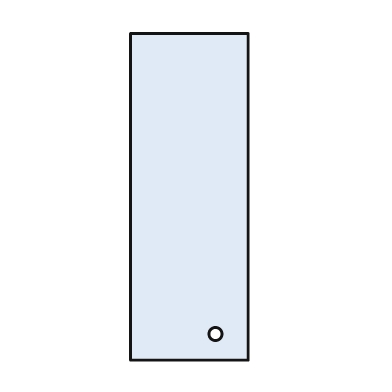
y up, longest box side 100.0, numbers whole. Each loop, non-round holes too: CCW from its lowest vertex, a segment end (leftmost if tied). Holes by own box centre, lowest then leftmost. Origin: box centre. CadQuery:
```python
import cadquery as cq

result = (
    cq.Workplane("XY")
    .moveTo(-18.0, -50.0)
    .lineTo(18.0, -50.0)
    .lineTo(18.0, 50.0)
    .lineTo(-18.0, 50.0)
    .close()
    .moveTo(8.0, -42.0)
    .circle(2.0)
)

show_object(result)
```